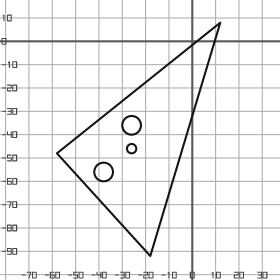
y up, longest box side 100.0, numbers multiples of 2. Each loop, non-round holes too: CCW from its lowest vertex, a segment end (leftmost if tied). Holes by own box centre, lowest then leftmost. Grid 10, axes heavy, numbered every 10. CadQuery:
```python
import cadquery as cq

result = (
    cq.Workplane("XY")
    .moveTo(-18.0, -92.0)
    .lineTo(12.0, 8.0)
    .lineTo(-58.0, -48.0)
    .close()
    .moveTo(-38.0, -56.0)
    .circle(4.0)
    .moveTo(-26.0, -46.0)
    .circle(2.0)
    .moveTo(-26.0, -36.0)
    .circle(4.0)
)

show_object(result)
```